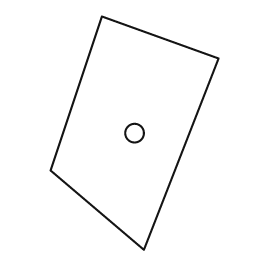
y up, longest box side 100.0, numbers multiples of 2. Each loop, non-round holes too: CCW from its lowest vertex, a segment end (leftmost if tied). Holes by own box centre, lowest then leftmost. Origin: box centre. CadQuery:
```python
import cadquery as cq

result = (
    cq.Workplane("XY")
    .moveTo(4.0, -50.0)
    .lineTo(36.0, 32.0)
    .lineTo(-14.0, 50.0)
    .lineTo(-36.0, -16.0)
    .close()
    .moveTo(0.0, 0.0)
    .circle(4.0)
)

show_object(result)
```